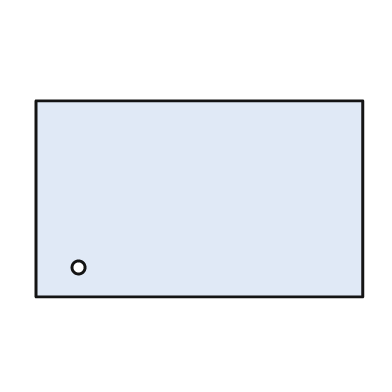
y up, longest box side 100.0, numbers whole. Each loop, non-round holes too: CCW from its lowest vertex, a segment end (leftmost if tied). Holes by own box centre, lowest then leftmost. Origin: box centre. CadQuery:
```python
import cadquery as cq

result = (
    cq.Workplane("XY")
    .moveTo(-50.0, -30.0)
    .lineTo(50.0, -30.0)
    .lineTo(50.0, 30.0)
    .lineTo(-50.0, 30.0)
    .close()
    .moveTo(-37.0, -21.0)
    .circle(2.0)
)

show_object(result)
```